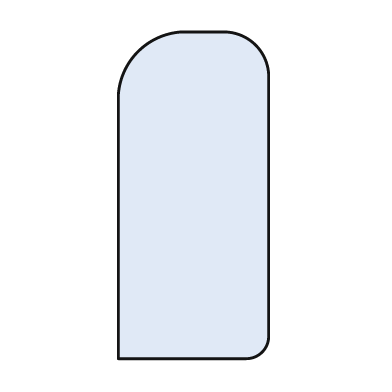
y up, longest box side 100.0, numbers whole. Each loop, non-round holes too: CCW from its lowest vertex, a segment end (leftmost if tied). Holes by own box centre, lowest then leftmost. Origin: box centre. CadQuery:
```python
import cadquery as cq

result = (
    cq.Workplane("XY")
    .moveTo(-23.0, -50.0)
    .lineTo(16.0, -50.0)
    .threePointArc((21.0, -48.0), (23.0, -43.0))
    .lineTo(23.0, 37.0)
    .threePointArc((19.0, 46.0), (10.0, 50.0))
    .lineTo(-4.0, 50.0)
    .threePointArc((-17.0, 44.0), (-23.0, 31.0))
    .close()
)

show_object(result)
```